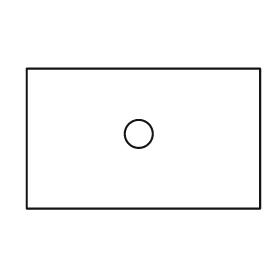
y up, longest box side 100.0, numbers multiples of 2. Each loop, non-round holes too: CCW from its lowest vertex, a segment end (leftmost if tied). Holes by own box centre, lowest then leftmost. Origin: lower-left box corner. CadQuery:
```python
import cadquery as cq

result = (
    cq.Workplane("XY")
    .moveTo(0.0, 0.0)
    .lineTo(100.0, 0.0)
    .lineTo(100.0, 60.0)
    .lineTo(0.0, 60.0)
    .close()
    .moveTo(48.0, 32.0)
    .circle(6.0)
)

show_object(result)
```